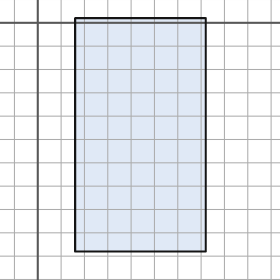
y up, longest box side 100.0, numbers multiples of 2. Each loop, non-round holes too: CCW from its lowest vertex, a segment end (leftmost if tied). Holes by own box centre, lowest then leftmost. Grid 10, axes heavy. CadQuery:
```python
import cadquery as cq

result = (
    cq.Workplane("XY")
    .moveTo(16.0, -98.0)
    .lineTo(72.0, -98.0)
    .lineTo(72.0, 2.0)
    .lineTo(16.0, 2.0)
    .close()
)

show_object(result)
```